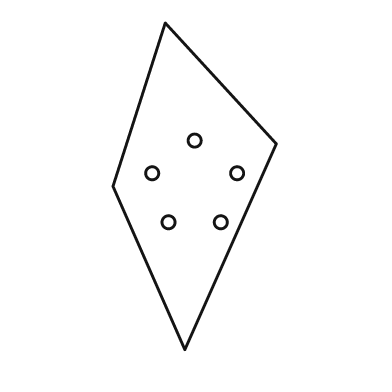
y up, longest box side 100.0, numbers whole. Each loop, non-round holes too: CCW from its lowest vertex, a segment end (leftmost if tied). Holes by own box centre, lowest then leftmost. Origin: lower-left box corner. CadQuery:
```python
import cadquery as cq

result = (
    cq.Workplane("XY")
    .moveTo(22.0, 0.0)
    .lineTo(50.0, 63.0)
    .lineTo(16.0, 100.0)
    .lineTo(0.0, 50.0)
    .close()
    .moveTo(17.0, 39.0)
    .circle(2.0)
    .moveTo(33.0, 39.0)
    .circle(2.0)
    .moveTo(12.0, 54.0)
    .circle(2.0)
    .moveTo(38.0, 54.0)
    .circle(2.0)
    .moveTo(25.0, 64.0)
    .circle(2.0)
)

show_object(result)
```